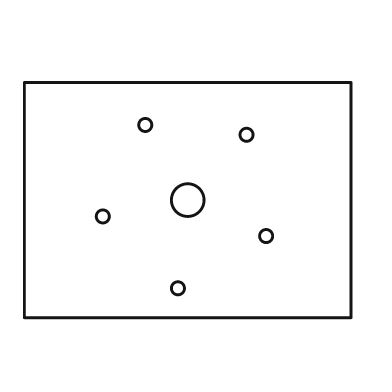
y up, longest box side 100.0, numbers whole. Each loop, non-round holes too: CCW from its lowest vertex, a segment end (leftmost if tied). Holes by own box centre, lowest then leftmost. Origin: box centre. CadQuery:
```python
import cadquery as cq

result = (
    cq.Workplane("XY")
    .moveTo(-50.0, -36.0)
    .lineTo(50.0, -36.0)
    .lineTo(50.0, 36.0)
    .lineTo(-50.0, 36.0)
    .close()
    .moveTo(-3.0, -27.0)
    .circle(2.0)
    .moveTo(24.0, -11.0)
    .circle(2.0)
    .moveTo(-26.0, -5.0)
    .circle(2.0)
    .moveTo(0.0, 0.0)
    .circle(5.0)
    .moveTo(18.0, 20.0)
    .circle(2.0)
    .moveTo(-13.0, 23.0)
    .circle(2.0)
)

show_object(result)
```